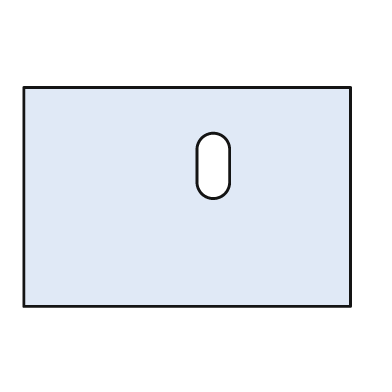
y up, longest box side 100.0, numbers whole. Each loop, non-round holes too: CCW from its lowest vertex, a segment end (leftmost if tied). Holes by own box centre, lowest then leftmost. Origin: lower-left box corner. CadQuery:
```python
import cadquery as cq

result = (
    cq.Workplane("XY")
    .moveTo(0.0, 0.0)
    .lineTo(100.0, 0.0)
    .lineTo(100.0, 67.0)
    .lineTo(0.0, 67.0)
    .close()
    .moveTo(53.0, 38.0)
    .threePointArc((58.0, 33.0), (63.0, 38.0))
    .lineTo(63.0, 48.0)
    .threePointArc((58.0, 53.0), (53.0, 48.0))
    .close()
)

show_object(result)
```